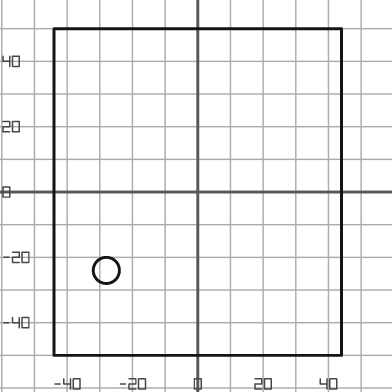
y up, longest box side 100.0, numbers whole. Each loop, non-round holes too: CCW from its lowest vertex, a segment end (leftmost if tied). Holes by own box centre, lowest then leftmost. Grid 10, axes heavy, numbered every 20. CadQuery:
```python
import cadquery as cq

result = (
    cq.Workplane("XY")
    .moveTo(-44.0, -50.0)
    .lineTo(44.0, -50.0)
    .lineTo(44.0, 50.0)
    .lineTo(-44.0, 50.0)
    .close()
    .moveTo(-28.0, -24.0)
    .circle(4.0)
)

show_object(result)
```